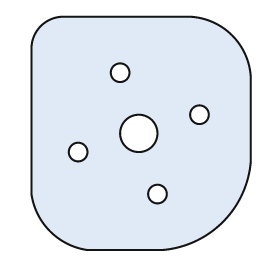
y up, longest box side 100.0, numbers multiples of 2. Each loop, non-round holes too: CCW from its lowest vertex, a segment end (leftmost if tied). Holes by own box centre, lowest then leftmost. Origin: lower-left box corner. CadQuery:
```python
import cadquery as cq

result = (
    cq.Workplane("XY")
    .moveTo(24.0, 0.0)
    .lineTo(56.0, 0.0)
    .threePointArc((82.0, 12.0), (94.0, 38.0))
    .lineTo(94.0, 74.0)
    .threePointArc((86.0, 92.0), (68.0, 100.0))
    .lineTo(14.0, 100.0)
    .threePointArc((4.0, 96.0), (0.0, 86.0))
    .lineTo(0.0, 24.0)
    .threePointArc((8.0, 8.0), (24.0, 0.0))
    .close()
    .moveTo(54.0, 24.0)
    .circle(4.0)
    .moveTo(20.0, 42.0)
    .circle(4.0)
    .moveTo(46.0, 50.0)
    .circle(8.0)
    .moveTo(72.0, 58.0)
    .circle(4.0)
    .moveTo(38.0, 76.0)
    .circle(4.0)
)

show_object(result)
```